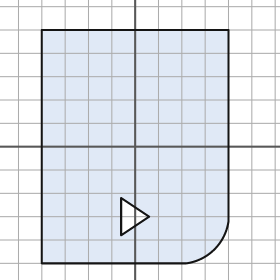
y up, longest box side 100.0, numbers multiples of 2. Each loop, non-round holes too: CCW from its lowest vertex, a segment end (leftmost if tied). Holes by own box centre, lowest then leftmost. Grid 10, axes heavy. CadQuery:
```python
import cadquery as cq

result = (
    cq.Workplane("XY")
    .moveTo(-40.0, -50.0)
    .lineTo(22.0, -50.0)
    .threePointArc((34.0, -44.0), (40.0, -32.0))
    .lineTo(40.0, 50.0)
    .lineTo(-40.0, 50.0)
    .close()
    .moveTo(-6.0, -38.0)
    .lineTo(6.0, -30.0)
    .lineTo(-6.0, -22.0)
    .close()
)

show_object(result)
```